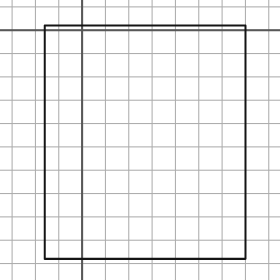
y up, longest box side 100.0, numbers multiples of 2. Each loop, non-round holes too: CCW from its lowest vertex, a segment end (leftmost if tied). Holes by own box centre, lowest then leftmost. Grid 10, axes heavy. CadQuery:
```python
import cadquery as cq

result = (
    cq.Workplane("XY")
    .moveTo(-16.0, -98.0)
    .lineTo(70.0, -98.0)
    .lineTo(70.0, 2.0)
    .lineTo(-16.0, 2.0)
    .close()
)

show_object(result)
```